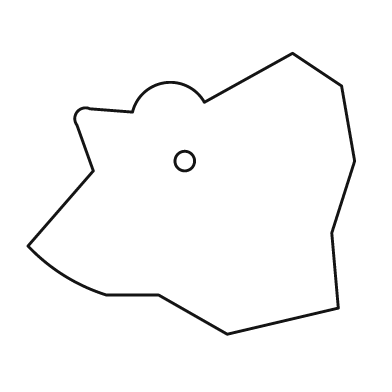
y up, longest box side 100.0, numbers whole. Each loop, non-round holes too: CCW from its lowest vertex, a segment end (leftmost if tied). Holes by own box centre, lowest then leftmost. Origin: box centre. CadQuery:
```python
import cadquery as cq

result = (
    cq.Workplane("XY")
    .moveTo(11.0, -43.0)
    .lineTo(45.0, -35.0)
    .lineTo(43.0, -12.0)
    .lineTo(50.0, 10.0)
    .lineTo(46.0, 33.0)
    .lineTo(31.0, 43.0)
    .lineTo(4.0, 28.0)
    .threePointArc((-8.0, 34.0), (-18.0, 25.0))
    .lineTo(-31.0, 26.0)
    .threePointArc((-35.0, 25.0), (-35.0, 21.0))
    .lineTo(-30.0, 7.0)
    .lineTo(-50.0, -16.0)
    .threePointArc((-39.0, -25.0), (-26.0, -31.0))
    .lineTo(-10.0, -31.0)
    .close()
    .moveTo(-2.0, 10.0)
    .circle(3.0)
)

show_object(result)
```